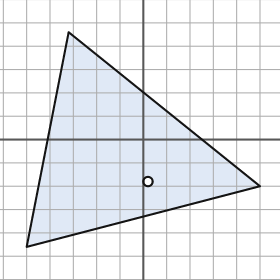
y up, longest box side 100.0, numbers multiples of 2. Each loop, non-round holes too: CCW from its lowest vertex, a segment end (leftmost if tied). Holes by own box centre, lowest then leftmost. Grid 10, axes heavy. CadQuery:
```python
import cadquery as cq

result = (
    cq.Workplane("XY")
    .moveTo(-50.0, -46.0)
    .lineTo(50.0, -20.0)
    .lineTo(-32.0, 46.0)
    .close()
    .moveTo(2.0, -18.0)
    .circle(2.0)
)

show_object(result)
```